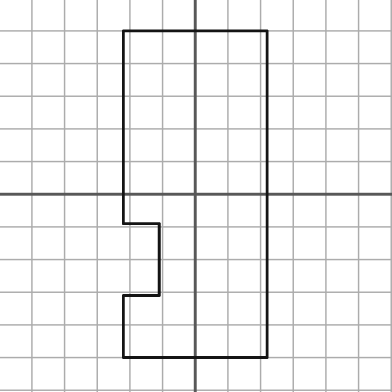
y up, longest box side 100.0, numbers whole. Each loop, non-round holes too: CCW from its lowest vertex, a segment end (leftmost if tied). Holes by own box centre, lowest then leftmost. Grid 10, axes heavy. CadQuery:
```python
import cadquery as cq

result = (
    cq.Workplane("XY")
    .moveTo(-22.0, -50.0)
    .lineTo(22.0, -50.0)
    .lineTo(22.0, 50.0)
    .lineTo(-22.0, 50.0)
    .lineTo(-22.0, -9.0)
    .lineTo(-11.0, -9.0)
    .lineTo(-11.0, -31.0)
    .lineTo(-22.0, -31.0)
    .close()
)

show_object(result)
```